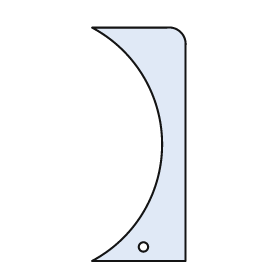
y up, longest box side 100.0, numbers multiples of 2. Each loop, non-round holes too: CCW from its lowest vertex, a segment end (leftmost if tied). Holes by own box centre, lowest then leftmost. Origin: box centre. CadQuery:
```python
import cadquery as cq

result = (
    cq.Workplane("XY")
    .moveTo(-20.0, -50.0)
    .lineTo(20.0, -50.0)
    .lineTo(20.0, 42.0)
    .threePointArc((18.0, 48.0), (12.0, 50.0))
    .lineTo(-20.0, 50.0)
    .threePointArc((10.0, 0.0), (-20.0, -50.0))
    .close()
    .moveTo(2.0, -44.0)
    .circle(2.0)
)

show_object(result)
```